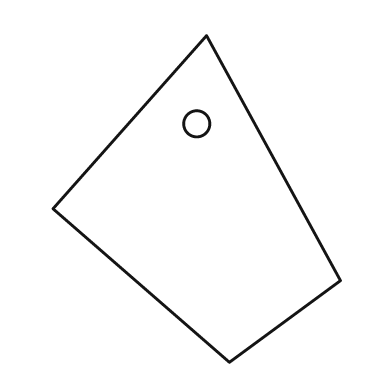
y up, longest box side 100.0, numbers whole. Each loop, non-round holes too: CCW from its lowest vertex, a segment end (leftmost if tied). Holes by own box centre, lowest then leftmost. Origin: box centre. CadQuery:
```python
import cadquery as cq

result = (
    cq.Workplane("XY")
    .moveTo(10.0, -50.0)
    .lineTo(44.0, -25.0)
    .lineTo(3.0, 50.0)
    .lineTo(-44.0, -3.0)
    .close()
    .moveTo(0.0, 23.0)
    .circle(4.0)
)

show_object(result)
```